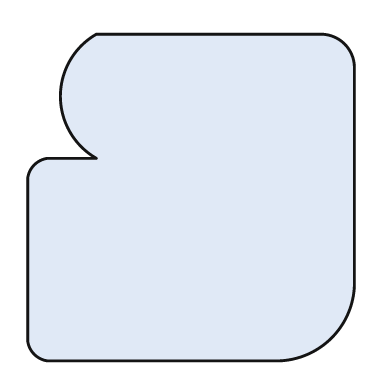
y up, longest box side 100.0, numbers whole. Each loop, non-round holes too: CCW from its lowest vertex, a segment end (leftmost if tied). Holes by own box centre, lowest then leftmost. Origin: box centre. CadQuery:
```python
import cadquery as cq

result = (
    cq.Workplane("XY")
    .moveTo(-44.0, -50.0)
    .lineTo(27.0, -50.0)
    .threePointArc((43.0, -43.0), (50.0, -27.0))
    .lineTo(50.0, 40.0)
    .threePointArc((47.0, 47.0), (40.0, 50.0))
    .lineTo(-29.0, 50.0)
    .threePointArc((-40.0, 31.0), (-29.0, 12.0))
    .lineTo(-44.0, 12.0)
    .threePointArc((-48.0, 10.0), (-50.0, 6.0))
    .lineTo(-50.0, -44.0)
    .threePointArc((-48.0, -48.0), (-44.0, -50.0))
    .close()
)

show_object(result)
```